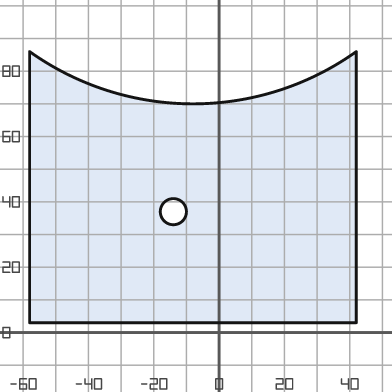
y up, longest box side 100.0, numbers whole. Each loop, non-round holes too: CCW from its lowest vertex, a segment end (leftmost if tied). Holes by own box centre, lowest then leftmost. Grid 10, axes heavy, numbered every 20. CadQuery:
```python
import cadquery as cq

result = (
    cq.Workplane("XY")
    .moveTo(-58.0, 3.0)
    .lineTo(42.0, 3.0)
    .lineTo(42.0, 86.0)
    .threePointArc((-8.0, 70.0), (-58.0, 86.0))
    .close()
    .moveTo(-14.0, 37.0)
    .circle(4.0)
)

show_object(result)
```